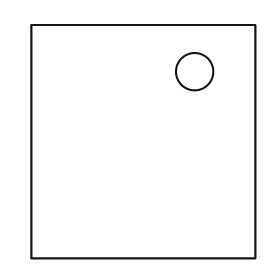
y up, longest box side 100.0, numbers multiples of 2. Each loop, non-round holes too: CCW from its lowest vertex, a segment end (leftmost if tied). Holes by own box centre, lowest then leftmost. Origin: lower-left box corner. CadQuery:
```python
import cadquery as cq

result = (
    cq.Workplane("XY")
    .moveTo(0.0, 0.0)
    .lineTo(96.0, 0.0)
    .lineTo(96.0, 100.0)
    .lineTo(0.0, 100.0)
    .close()
    .moveTo(70.0, 80.0)
    .circle(8.0)
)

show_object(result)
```